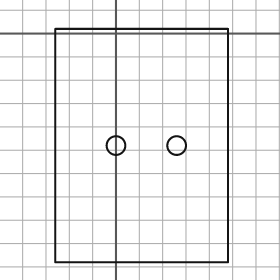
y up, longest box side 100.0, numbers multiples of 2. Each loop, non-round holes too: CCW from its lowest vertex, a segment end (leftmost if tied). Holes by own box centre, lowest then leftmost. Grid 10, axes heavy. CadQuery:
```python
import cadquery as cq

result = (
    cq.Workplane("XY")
    .moveTo(-26.0, -98.0)
    .lineTo(48.0, -98.0)
    .lineTo(48.0, 2.0)
    .lineTo(-26.0, 2.0)
    .close()
    .moveTo(0.0, -48.0)
    .circle(4.0)
    .moveTo(26.0, -48.0)
    .circle(4.0)
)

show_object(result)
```